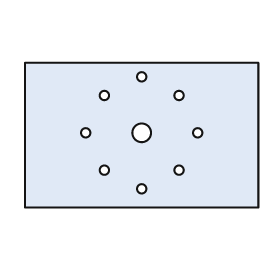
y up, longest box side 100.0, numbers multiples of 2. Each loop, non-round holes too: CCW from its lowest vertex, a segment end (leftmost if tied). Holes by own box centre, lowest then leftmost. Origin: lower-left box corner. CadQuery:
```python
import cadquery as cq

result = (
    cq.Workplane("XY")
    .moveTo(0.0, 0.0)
    .lineTo(100.0, 0.0)
    .lineTo(100.0, 62.0)
    .lineTo(0.0, 62.0)
    .close()
    .moveTo(50.0, 8.0)
    .circle(2.0)
    .moveTo(34.0, 16.0)
    .circle(2.0)
    .moveTo(66.0, 16.0)
    .circle(2.0)
    .moveTo(26.0, 32.0)
    .circle(2.0)
    .moveTo(50.0, 32.0)
    .circle(4.0)
    .moveTo(74.0, 32.0)
    .circle(2.0)
    .moveTo(34.0, 48.0)
    .circle(2.0)
    .moveTo(66.0, 48.0)
    .circle(2.0)
    .moveTo(50.0, 56.0)
    .circle(2.0)
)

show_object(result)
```